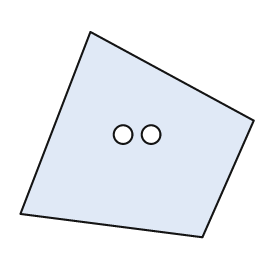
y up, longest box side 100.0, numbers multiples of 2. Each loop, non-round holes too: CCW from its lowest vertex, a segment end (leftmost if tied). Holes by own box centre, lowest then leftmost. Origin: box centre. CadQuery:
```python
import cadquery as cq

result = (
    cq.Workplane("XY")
    .moveTo(28.0, -44.0)
    .lineTo(50.0, 6.0)
    .lineTo(-20.0, 44.0)
    .lineTo(-50.0, -34.0)
    .close()
    .moveTo(-6.0, 0.0)
    .circle(4.0)
    .moveTo(6.0, 0.0)
    .circle(4.0)
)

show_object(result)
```